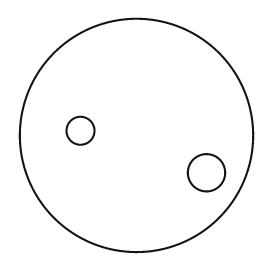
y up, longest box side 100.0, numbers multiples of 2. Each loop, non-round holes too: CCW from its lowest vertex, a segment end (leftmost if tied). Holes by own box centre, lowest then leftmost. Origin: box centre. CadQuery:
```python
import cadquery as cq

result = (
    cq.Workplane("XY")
    .moveTo(0.0, 0.0)
    .circle(50.0)
    .moveTo(30.0, -16.0)
    .circle(8.0)
    .moveTo(-24.0, 2.0)
    .circle(6.0)
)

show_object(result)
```